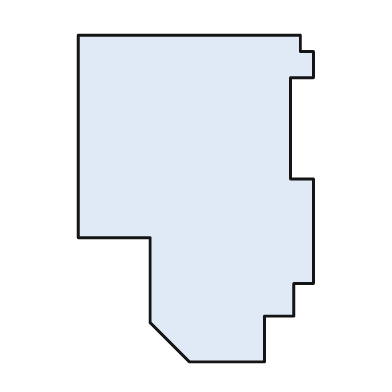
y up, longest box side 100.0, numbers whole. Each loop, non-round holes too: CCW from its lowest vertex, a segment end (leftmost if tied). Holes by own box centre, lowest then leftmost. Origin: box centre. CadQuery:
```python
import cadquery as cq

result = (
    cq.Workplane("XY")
    .moveTo(-2.0, -50.0)
    .lineTo(21.0, -50.0)
    .lineTo(21.0, -36.0)
    .lineTo(30.0, -36.0)
    .lineTo(30.0, -26.0)
    .lineTo(36.0, -26.0)
    .lineTo(36.0, 6.0)
    .lineTo(29.0, 6.0)
    .lineTo(29.0, 37.0)
    .lineTo(36.0, 37.0)
    .lineTo(36.0, 45.0)
    .lineTo(32.0, 45.0)
    .lineTo(32.0, 50.0)
    .lineTo(-36.0, 50.0)
    .lineTo(-36.0, -12.0)
    .lineTo(-14.0, -12.0)
    .lineTo(-14.0, -38.0)
    .close()
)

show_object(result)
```